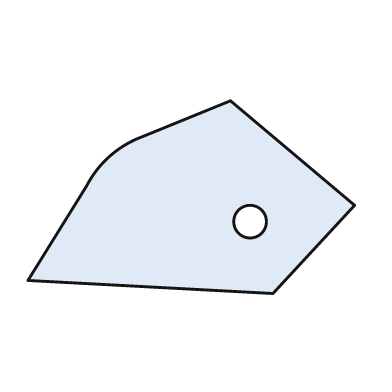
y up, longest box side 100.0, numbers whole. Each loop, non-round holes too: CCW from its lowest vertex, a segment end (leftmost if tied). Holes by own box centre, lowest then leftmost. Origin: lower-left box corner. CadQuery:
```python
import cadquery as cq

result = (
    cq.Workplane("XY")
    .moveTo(75.0, 0.0)
    .lineTo(100.0, 27.0)
    .lineTo(62.0, 59.0)
    .lineTo(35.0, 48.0)
    .threePointArc((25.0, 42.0), (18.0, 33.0))
    .lineTo(0.0, 4.0)
    .close()
    .moveTo(68.0, 22.0)
    .circle(5.0)
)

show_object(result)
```